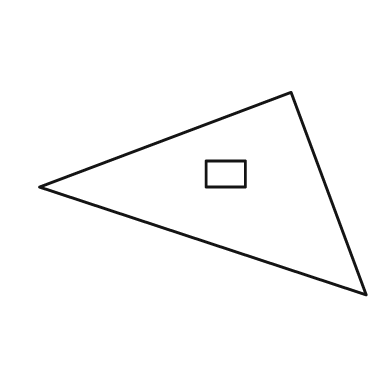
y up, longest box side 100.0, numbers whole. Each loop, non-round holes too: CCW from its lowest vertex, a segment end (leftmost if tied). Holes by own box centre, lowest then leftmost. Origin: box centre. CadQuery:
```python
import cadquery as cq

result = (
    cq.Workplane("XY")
    .moveTo(50.0, -31.0)
    .lineTo(27.0, 31.0)
    .lineTo(-50.0, 2.0)
    .close()
    .moveTo(1.0, 2.0)
    .lineTo(13.0, 2.0)
    .lineTo(13.0, 10.0)
    .lineTo(1.0, 10.0)
    .close()
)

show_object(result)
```